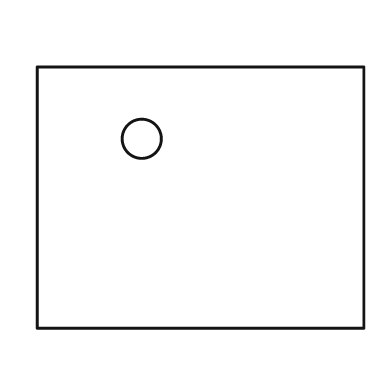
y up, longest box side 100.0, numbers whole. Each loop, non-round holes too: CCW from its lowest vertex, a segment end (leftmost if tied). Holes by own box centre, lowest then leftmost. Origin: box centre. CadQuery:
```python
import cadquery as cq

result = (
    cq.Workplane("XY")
    .moveTo(-50.0, -40.0)
    .lineTo(50.0, -40.0)
    .lineTo(50.0, 40.0)
    .lineTo(-50.0, 40.0)
    .close()
    .moveTo(-18.0, 18.0)
    .circle(6.0)
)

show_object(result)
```